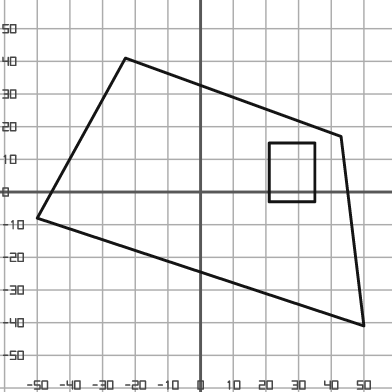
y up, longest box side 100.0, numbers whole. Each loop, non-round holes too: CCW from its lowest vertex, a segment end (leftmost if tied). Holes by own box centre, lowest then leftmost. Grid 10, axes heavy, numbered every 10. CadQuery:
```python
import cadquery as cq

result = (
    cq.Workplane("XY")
    .moveTo(50.0, -41.0)
    .lineTo(43.0, 17.0)
    .lineTo(-23.0, 41.0)
    .lineTo(-50.0, -8.0)
    .close()
    .moveTo(21.0, -3.0)
    .lineTo(35.0, -3.0)
    .lineTo(35.0, 15.0)
    .lineTo(21.0, 15.0)
    .close()
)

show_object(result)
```